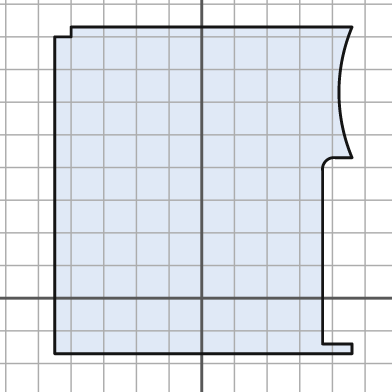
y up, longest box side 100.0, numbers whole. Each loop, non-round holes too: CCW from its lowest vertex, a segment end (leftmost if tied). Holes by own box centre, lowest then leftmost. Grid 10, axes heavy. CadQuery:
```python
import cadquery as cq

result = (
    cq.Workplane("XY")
    .moveTo(-45.0, -17.0)
    .lineTo(46.0, -17.0)
    .lineTo(46.0, -14.0)
    .lineTo(37.0, -14.0)
    .lineTo(37.0, 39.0)
    .threePointArc((38.0, 42.0), (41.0, 43.0))
    .lineTo(46.0, 43.0)
    .threePointArc((42.0, 63.0), (46.0, 83.0))
    .lineTo(-40.0, 83.0)
    .lineTo(-40.0, 80.0)
    .lineTo(-45.0, 80.0)
    .close()
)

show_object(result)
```